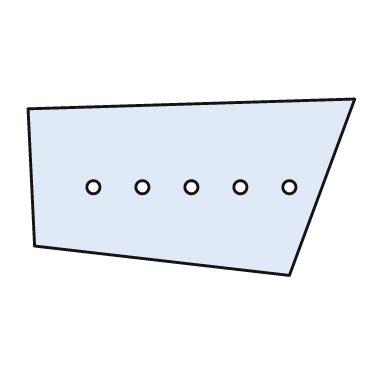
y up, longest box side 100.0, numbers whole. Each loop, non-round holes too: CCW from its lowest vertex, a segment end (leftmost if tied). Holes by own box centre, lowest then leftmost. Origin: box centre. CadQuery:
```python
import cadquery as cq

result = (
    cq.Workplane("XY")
    .moveTo(30.0, -27.0)
    .lineTo(50.0, 27.0)
    .lineTo(-50.0, 24.0)
    .lineTo(-48.0, -18.0)
    .close()
    .moveTo(-30.0, 0.0)
    .circle(2.0)
    .moveTo(-15.0, 0.0)
    .circle(2.0)
    .moveTo(0.0, 0.0)
    .circle(2.0)
    .moveTo(15.0, 0.0)
    .circle(2.0)
    .moveTo(30.0, 0.0)
    .circle(2.0)
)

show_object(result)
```